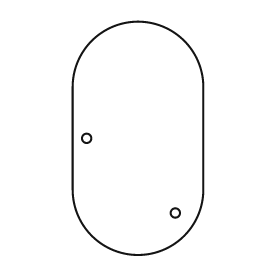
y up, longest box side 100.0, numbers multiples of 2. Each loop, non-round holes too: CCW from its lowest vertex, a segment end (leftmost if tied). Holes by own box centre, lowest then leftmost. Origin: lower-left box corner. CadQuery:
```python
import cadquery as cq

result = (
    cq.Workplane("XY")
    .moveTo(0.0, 28.0)
    .threePointArc((28.0, 0.0), (56.0, 28.0))
    .lineTo(56.0, 72.0)
    .threePointArc((28.0, 100.0), (0.0, 72.0))
    .close()
    .moveTo(44.0, 18.0)
    .circle(2.0)
    .moveTo(6.0, 50.0)
    .circle(2.0)
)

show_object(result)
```